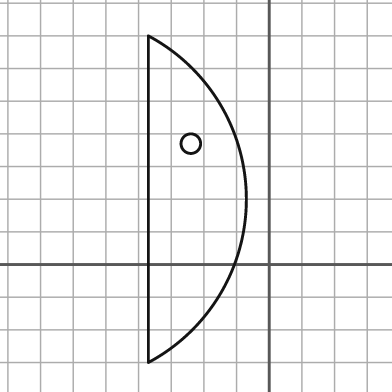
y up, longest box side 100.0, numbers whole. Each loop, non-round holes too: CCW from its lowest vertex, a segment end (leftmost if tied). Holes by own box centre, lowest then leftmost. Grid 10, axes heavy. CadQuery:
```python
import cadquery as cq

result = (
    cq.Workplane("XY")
    .moveTo(-37.0, -30.0)
    .threePointArc((-7.0, 20.0), (-37.0, 70.0))
    .close()
    .moveTo(-24.0, 37.0)
    .circle(3.0)
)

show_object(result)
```